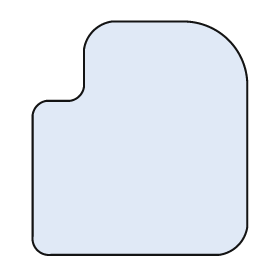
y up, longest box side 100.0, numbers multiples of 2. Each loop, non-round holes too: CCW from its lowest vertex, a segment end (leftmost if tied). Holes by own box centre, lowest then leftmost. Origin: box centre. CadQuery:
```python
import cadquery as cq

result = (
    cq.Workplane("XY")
    .moveTo(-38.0, -50.0)
    .lineTo(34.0, -50.0)
    .threePointArc((42.0, -46.0), (46.0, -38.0))
    .lineTo(46.0, 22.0)
    .threePointArc((38.0, 42.0), (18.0, 50.0))
    .lineTo(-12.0, 50.0)
    .threePointArc((-20.0, 46.0), (-24.0, 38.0))
    .lineTo(-24.0, 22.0)
    .threePointArc((-26.0, 18.0), (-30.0, 16.0))
    .lineTo(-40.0, 16.0)
    .threePointArc((-44.0, 14.0), (-46.0, 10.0))
    .lineTo(-46.0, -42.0)
    .threePointArc((-44.0, -48.0), (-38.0, -50.0))
    .close()
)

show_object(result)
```